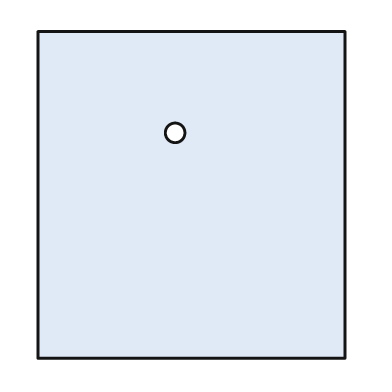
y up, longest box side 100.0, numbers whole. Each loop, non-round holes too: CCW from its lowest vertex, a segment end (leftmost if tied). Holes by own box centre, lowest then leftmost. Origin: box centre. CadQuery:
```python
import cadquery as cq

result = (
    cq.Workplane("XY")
    .moveTo(-47.0, -50.0)
    .lineTo(47.0, -50.0)
    .lineTo(47.0, 50.0)
    .lineTo(-47.0, 50.0)
    .close()
    .moveTo(-5.0, 19.0)
    .circle(3.0)
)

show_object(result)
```